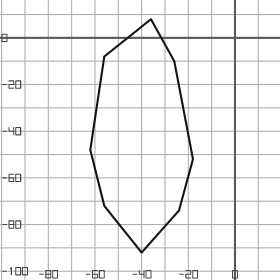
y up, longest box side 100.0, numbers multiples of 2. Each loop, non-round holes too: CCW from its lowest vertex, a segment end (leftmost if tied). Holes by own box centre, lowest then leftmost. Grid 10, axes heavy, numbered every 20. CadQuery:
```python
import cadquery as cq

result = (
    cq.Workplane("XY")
    .moveTo(-40.0, -92.0)
    .lineTo(-24.0, -74.0)
    .lineTo(-18.0, -52.0)
    .lineTo(-26.0, -10.0)
    .lineTo(-36.0, 8.0)
    .lineTo(-56.0, -8.0)
    .lineTo(-62.0, -48.0)
    .lineTo(-56.0, -72.0)
    .close()
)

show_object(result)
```